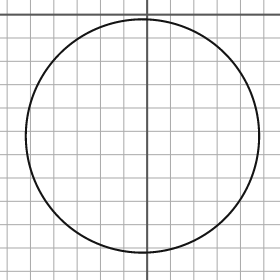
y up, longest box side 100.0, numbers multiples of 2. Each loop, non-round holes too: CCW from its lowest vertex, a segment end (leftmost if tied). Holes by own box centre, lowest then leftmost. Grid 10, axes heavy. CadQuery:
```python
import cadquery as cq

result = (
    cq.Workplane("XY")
    .moveTo(-2.0, -52.0)
    .circle(50.0)
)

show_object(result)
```